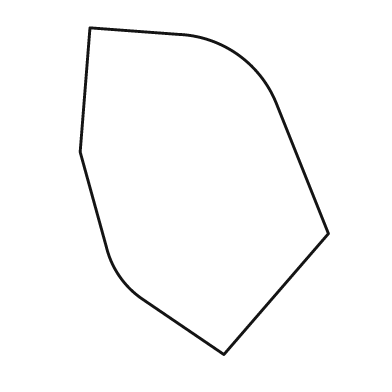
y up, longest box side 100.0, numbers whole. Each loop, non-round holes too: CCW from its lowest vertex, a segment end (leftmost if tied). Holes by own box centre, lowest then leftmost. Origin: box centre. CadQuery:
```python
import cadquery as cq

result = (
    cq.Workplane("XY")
    .moveTo(6.0, -50.0)
    .lineTo(38.0, -13.0)
    .lineTo(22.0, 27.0)
    .threePointArc((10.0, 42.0), (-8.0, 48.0))
    .lineTo(-35.0, 50.0)
    .lineTo(-38.0, 12.0)
    .lineTo(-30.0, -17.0)
    .threePointArc((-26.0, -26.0), (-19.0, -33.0))
    .close()
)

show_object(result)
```